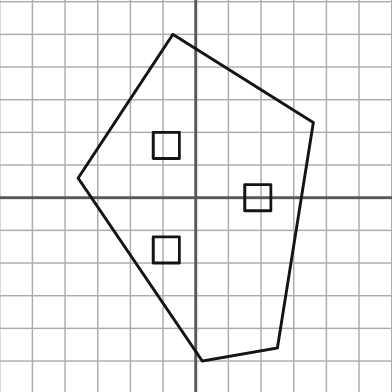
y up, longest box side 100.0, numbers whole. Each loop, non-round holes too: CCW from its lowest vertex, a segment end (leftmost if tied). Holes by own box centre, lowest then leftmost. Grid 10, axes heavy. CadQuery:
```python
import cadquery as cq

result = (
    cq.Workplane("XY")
    .moveTo(2.0, -50.0)
    .lineTo(25.0, -46.0)
    .lineTo(36.0, 23.0)
    .lineTo(-7.0, 50.0)
    .lineTo(-36.0, 6.0)
    .close()
    .moveTo(-13.0, -20.0)
    .lineTo(-5.0, -20.0)
    .lineTo(-5.0, -12.0)
    .lineTo(-13.0, -12.0)
    .close()
    .moveTo(15.0, -4.0)
    .lineTo(23.0, -4.0)
    .lineTo(23.0, 4.0)
    .lineTo(15.0, 4.0)
    .close()
    .moveTo(-13.0, 12.0)
    .lineTo(-5.0, 12.0)
    .lineTo(-5.0, 20.0)
    .lineTo(-13.0, 20.0)
    .close()
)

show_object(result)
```